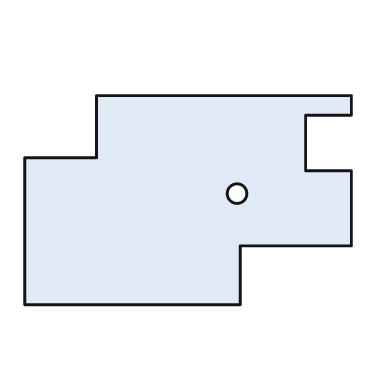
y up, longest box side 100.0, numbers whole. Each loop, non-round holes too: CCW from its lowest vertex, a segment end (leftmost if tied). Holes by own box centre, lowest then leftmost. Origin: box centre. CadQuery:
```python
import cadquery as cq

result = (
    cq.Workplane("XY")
    .moveTo(-50.0, -32.0)
    .lineTo(16.0, -32.0)
    .lineTo(16.0, -14.0)
    .lineTo(50.0, -14.0)
    .lineTo(50.0, 9.0)
    .lineTo(36.0, 9.0)
    .lineTo(36.0, 26.0)
    .lineTo(50.0, 26.0)
    .lineTo(50.0, 32.0)
    .lineTo(-28.0, 32.0)
    .lineTo(-28.0, 13.0)
    .lineTo(-50.0, 13.0)
    .close()
    .moveTo(15.0, 2.0)
    .circle(3.0)
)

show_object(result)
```